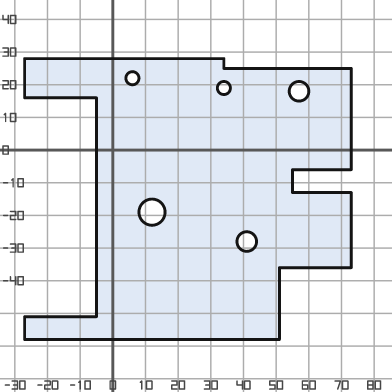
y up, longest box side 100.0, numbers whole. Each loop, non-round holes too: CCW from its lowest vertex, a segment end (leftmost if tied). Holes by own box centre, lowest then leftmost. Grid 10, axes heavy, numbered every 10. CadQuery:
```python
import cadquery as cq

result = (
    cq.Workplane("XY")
    .moveTo(-27.0, -58.0)
    .lineTo(51.0, -58.0)
    .lineTo(51.0, -36.0)
    .lineTo(73.0, -36.0)
    .lineTo(73.0, -13.0)
    .lineTo(55.0, -13.0)
    .lineTo(55.0, -6.0)
    .lineTo(73.0, -6.0)
    .lineTo(73.0, 25.0)
    .lineTo(34.0, 25.0)
    .lineTo(34.0, 28.0)
    .lineTo(-27.0, 28.0)
    .lineTo(-27.0, 16.0)
    .lineTo(-5.0, 16.0)
    .lineTo(-5.0, -51.0)
    .lineTo(-27.0, -51.0)
    .close()
    .moveTo(41.0, -28.0)
    .circle(3.0)
    .moveTo(12.0, -19.0)
    .circle(4.0)
    .moveTo(57.0, 18.0)
    .circle(3.0)
    .moveTo(34.0, 19.0)
    .circle(2.0)
    .moveTo(6.0, 22.0)
    .circle(2.0)
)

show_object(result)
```